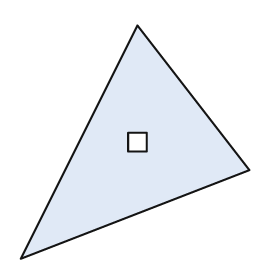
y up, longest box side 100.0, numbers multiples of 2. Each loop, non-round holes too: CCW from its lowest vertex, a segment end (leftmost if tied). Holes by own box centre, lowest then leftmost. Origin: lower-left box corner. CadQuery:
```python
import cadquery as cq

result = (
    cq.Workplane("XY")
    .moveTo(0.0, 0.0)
    .lineTo(98.0, 38.0)
    .lineTo(50.0, 100.0)
    .close()
    .moveTo(46.0, 46.0)
    .lineTo(54.0, 46.0)
    .lineTo(54.0, 54.0)
    .lineTo(46.0, 54.0)
    .close()
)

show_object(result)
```